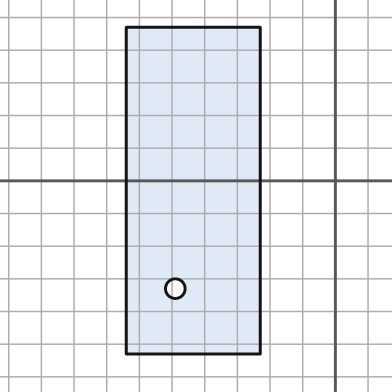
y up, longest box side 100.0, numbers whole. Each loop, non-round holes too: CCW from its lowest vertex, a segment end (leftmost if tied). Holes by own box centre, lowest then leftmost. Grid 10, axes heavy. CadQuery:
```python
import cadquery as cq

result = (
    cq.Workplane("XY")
    .moveTo(-64.0, -53.0)
    .lineTo(-23.0, -53.0)
    .lineTo(-23.0, 47.0)
    .lineTo(-64.0, 47.0)
    .close()
    .moveTo(-49.0, -33.0)
    .circle(3.0)
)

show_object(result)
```